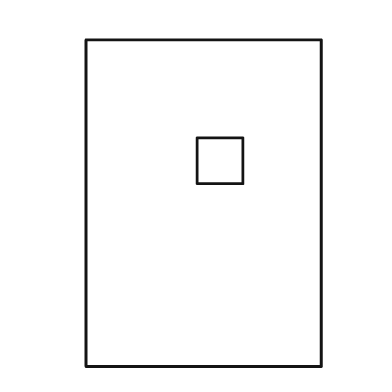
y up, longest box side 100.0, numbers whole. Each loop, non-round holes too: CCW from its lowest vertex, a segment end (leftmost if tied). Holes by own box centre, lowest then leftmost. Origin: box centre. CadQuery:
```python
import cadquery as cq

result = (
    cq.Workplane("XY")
    .moveTo(-36.0, -50.0)
    .lineTo(36.0, -50.0)
    .lineTo(36.0, 50.0)
    .lineTo(-36.0, 50.0)
    .close()
    .moveTo(-2.0, 6.0)
    .lineTo(12.0, 6.0)
    .lineTo(12.0, 20.0)
    .lineTo(-2.0, 20.0)
    .close()
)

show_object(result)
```